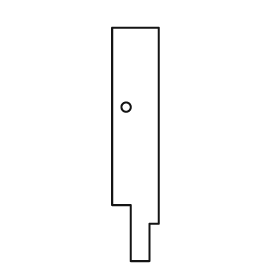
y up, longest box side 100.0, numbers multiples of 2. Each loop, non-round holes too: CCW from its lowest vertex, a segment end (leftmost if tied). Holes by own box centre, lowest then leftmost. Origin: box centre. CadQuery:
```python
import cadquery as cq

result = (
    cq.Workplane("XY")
    .moveTo(-2.0, -50.0)
    .lineTo(6.0, -50.0)
    .lineTo(6.0, -34.0)
    .lineTo(10.0, -34.0)
    .lineTo(10.0, 50.0)
    .lineTo(-10.0, 50.0)
    .lineTo(-10.0, -26.0)
    .lineTo(-2.0, -26.0)
    .close()
    .moveTo(-4.0, 16.0)
    .circle(2.0)
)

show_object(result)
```